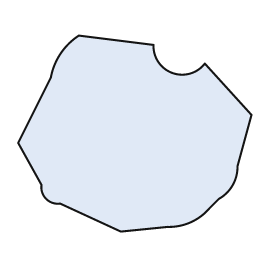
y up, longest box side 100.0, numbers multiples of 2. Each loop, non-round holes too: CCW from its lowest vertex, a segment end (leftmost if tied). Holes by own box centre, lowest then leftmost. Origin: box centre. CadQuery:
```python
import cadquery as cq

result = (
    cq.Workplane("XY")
    .moveTo(-6.0, -42.0)
    .lineTo(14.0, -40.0)
    .threePointArc((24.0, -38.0), (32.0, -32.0))
    .lineTo(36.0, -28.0)
    .threePointArc((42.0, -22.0), (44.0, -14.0))
    .lineTo(50.0, 8.0)
    .lineTo(30.0, 30.0)
    .threePointArc((16.0, 26.0), (8.0, 38.0))
    .lineTo(-24.0, 42.0)
    .threePointArc((-32.0, 34.0), (-36.0, 24.0))
    .lineTo(-50.0, -4.0)
    .lineTo(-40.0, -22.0)
    .threePointArc((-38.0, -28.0), (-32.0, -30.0))
    .close()
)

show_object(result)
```